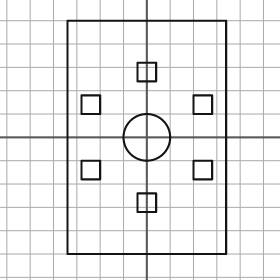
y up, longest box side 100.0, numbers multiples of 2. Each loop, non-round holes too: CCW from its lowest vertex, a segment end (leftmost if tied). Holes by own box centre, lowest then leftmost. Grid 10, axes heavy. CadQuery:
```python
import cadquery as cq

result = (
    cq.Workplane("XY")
    .moveTo(-34.0, -50.0)
    .lineTo(34.0, -50.0)
    .lineTo(34.0, 50.0)
    .lineTo(-34.0, 50.0)
    .close()
    .moveTo(-4.0, -32.0)
    .lineTo(4.0, -32.0)
    .lineTo(4.0, -24.0)
    .lineTo(-4.0, -24.0)
    .close()
    .moveTo(-28.0, -18.0)
    .lineTo(-20.0, -18.0)
    .lineTo(-20.0, -10.0)
    .lineTo(-28.0, -10.0)
    .close()
    .moveTo(20.0, -18.0)
    .lineTo(28.0, -18.0)
    .lineTo(28.0, -10.0)
    .lineTo(20.0, -10.0)
    .close()
    .moveTo(0.0, 0.0)
    .circle(10.0)
    .moveTo(-28.0, 10.0)
    .lineTo(-20.0, 10.0)
    .lineTo(-20.0, 18.0)
    .lineTo(-28.0, 18.0)
    .close()
    .moveTo(20.0, 10.0)
    .lineTo(28.0, 10.0)
    .lineTo(28.0, 18.0)
    .lineTo(20.0, 18.0)
    .close()
    .moveTo(-4.0, 24.0)
    .lineTo(4.0, 24.0)
    .lineTo(4.0, 32.0)
    .lineTo(-4.0, 32.0)
    .close()
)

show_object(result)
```